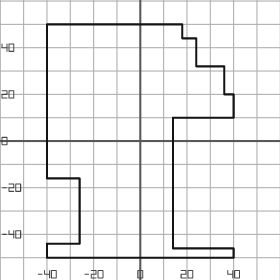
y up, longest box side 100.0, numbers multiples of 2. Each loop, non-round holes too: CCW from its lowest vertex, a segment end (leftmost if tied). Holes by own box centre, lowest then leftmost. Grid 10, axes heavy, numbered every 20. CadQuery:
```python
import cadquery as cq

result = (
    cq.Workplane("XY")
    .moveTo(-40.0, -50.0)
    .lineTo(40.0, -50.0)
    .lineTo(40.0, -46.0)
    .lineTo(14.0, -46.0)
    .lineTo(14.0, 10.0)
    .lineTo(40.0, 10.0)
    .lineTo(40.0, 20.0)
    .lineTo(36.0, 20.0)
    .lineTo(36.0, 32.0)
    .lineTo(24.0, 32.0)
    .lineTo(24.0, 44.0)
    .lineTo(18.0, 44.0)
    .lineTo(18.0, 50.0)
    .lineTo(-40.0, 50.0)
    .lineTo(-40.0, -16.0)
    .lineTo(-26.0, -16.0)
    .lineTo(-26.0, -44.0)
    .lineTo(-40.0, -44.0)
    .close()
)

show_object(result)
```